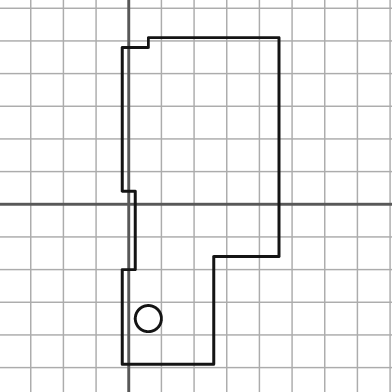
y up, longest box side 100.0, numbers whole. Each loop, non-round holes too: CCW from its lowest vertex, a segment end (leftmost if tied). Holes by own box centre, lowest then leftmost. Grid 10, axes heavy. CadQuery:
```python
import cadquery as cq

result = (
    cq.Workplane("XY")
    .moveTo(-2.0, -49.0)
    .lineTo(26.0, -49.0)
    .lineTo(26.0, -16.0)
    .lineTo(46.0, -16.0)
    .lineTo(46.0, 51.0)
    .lineTo(6.0, 51.0)
    .lineTo(6.0, 48.0)
    .lineTo(-2.0, 48.0)
    .lineTo(-2.0, 4.0)
    .lineTo(2.0, 4.0)
    .lineTo(2.0, -20.0)
    .lineTo(-2.0, -20.0)
    .close()
    .moveTo(6.0, -35.0)
    .circle(4.0)
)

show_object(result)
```